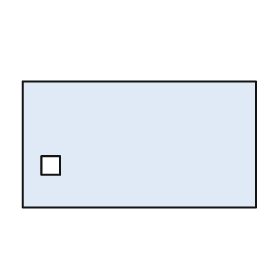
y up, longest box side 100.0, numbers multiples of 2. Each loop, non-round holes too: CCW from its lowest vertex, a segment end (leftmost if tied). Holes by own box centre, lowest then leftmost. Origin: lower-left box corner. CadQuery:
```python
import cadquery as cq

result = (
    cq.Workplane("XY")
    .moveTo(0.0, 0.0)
    .lineTo(100.0, 0.0)
    .lineTo(100.0, 54.0)
    .lineTo(0.0, 54.0)
    .close()
    .moveTo(8.0, 14.0)
    .lineTo(16.0, 14.0)
    .lineTo(16.0, 22.0)
    .lineTo(8.0, 22.0)
    .close()
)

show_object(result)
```